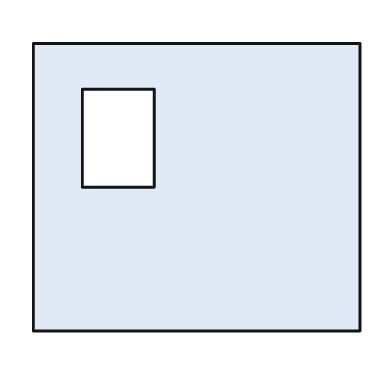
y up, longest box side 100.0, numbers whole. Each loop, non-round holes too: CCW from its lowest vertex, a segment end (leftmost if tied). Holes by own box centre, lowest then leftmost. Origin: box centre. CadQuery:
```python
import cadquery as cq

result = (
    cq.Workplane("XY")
    .moveTo(-50.0, -44.0)
    .lineTo(50.0, -44.0)
    .lineTo(50.0, 44.0)
    .lineTo(-50.0, 44.0)
    .close()
    .moveTo(-35.0, 0.0)
    .lineTo(-13.0, 0.0)
    .lineTo(-13.0, 30.0)
    .lineTo(-35.0, 30.0)
    .close()
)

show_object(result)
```